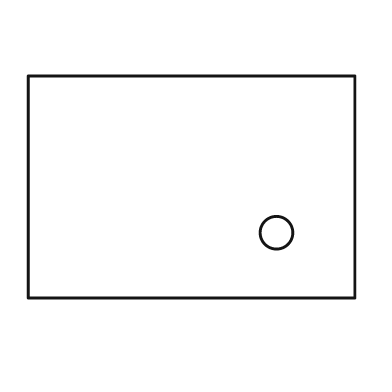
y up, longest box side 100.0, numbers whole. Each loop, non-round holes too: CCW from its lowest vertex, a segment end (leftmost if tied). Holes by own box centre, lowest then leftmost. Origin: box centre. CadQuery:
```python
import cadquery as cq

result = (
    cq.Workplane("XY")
    .moveTo(-50.0, -34.0)
    .lineTo(50.0, -34.0)
    .lineTo(50.0, 34.0)
    .lineTo(-50.0, 34.0)
    .close()
    .moveTo(26.0, -14.0)
    .circle(5.0)
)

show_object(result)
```